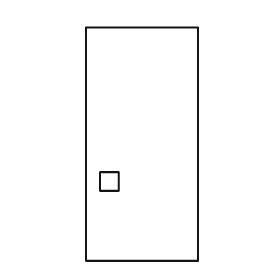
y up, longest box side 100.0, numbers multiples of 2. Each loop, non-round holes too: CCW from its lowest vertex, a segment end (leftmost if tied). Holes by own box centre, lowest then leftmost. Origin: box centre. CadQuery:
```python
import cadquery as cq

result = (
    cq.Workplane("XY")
    .moveTo(-24.0, -50.0)
    .lineTo(24.0, -50.0)
    .lineTo(24.0, 50.0)
    .lineTo(-24.0, 50.0)
    .close()
    .moveTo(-18.0, -20.0)
    .lineTo(-10.0, -20.0)
    .lineTo(-10.0, -12.0)
    .lineTo(-18.0, -12.0)
    .close()
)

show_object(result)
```